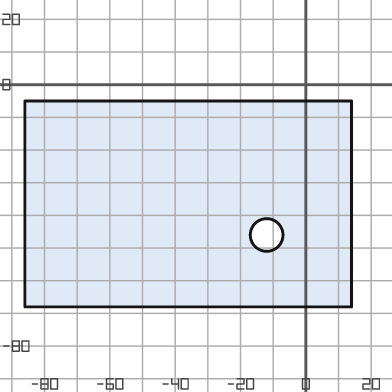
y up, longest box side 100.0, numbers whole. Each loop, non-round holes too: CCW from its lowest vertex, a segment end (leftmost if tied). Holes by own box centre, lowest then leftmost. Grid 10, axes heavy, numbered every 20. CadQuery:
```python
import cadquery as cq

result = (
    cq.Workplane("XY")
    .moveTo(-86.0, -68.0)
    .lineTo(14.0, -68.0)
    .lineTo(14.0, -5.0)
    .lineTo(-86.0, -5.0)
    .close()
    .moveTo(-12.0, -46.0)
    .circle(5.0)
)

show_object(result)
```